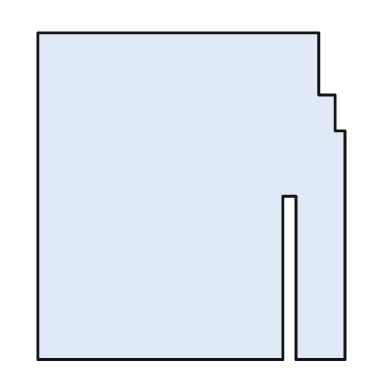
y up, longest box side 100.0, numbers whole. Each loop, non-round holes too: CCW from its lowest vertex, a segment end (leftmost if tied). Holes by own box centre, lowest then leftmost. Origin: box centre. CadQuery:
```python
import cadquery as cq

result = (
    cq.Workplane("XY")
    .moveTo(-47.0, -50.0)
    .lineTo(28.0, -50.0)
    .lineTo(28.0, 0.0)
    .lineTo(32.0, 0.0)
    .lineTo(32.0, -50.0)
    .lineTo(47.0, -50.0)
    .lineTo(47.0, 20.0)
    .lineTo(44.0, 20.0)
    .lineTo(44.0, 31.0)
    .lineTo(39.0, 31.0)
    .lineTo(39.0, 50.0)
    .lineTo(-47.0, 50.0)
    .close()
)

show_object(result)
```